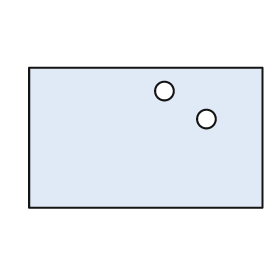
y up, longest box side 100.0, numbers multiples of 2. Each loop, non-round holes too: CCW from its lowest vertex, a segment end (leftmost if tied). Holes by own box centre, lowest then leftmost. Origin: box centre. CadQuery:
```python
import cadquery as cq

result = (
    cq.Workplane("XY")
    .moveTo(-50.0, -30.0)
    .lineTo(50.0, -30.0)
    .lineTo(50.0, 30.0)
    .lineTo(-50.0, 30.0)
    .close()
    .moveTo(26.0, 8.0)
    .circle(4.0)
    .moveTo(8.0, 20.0)
    .circle(4.0)
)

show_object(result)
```